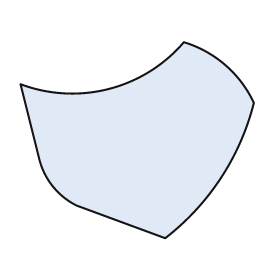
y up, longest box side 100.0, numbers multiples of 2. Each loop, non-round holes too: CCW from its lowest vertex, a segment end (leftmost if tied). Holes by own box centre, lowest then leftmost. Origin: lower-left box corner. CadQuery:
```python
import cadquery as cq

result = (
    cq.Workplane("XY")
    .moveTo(62.0, 0.0)
    .threePointArc((86.0, 26.0), (100.0, 58.0))
    .threePointArc((88.0, 74.0), (70.0, 84.0))
    .threePointArc((38.0, 64.0), (0.0, 66.0))
    .lineTo(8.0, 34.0)
    .threePointArc((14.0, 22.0), (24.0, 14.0))
    .close()
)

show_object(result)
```